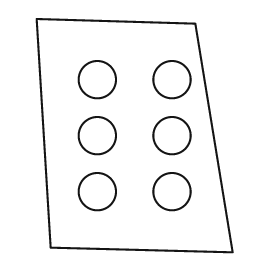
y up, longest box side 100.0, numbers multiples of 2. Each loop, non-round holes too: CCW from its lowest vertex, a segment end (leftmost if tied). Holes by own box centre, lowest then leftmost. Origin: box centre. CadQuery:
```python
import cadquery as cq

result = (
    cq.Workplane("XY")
    .moveTo(42.0, -50.0)
    .lineTo(26.0, 48.0)
    .lineTo(-42.0, 50.0)
    .lineTo(-36.0, -48.0)
    .close()
    .moveTo(-16.0, -24.0)
    .circle(8.0)
    .moveTo(16.0, -24.0)
    .circle(8.0)
    .moveTo(-16.0, 0.0)
    .circle(8.0)
    .moveTo(16.0, 0.0)
    .circle(8.0)
    .moveTo(-16.0, 24.0)
    .circle(8.0)
    .moveTo(16.0, 24.0)
    .circle(8.0)
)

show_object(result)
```